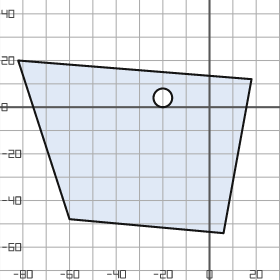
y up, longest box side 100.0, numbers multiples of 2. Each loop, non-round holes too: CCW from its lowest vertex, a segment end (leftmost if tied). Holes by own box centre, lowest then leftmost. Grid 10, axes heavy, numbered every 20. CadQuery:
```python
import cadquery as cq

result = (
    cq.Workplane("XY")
    .moveTo(6.0, -54.0)
    .lineTo(18.0, 12.0)
    .lineTo(-82.0, 20.0)
    .lineTo(-60.0, -48.0)
    .close()
    .moveTo(-20.0, 4.0)
    .circle(4.0)
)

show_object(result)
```